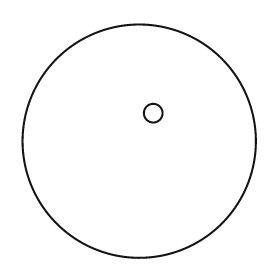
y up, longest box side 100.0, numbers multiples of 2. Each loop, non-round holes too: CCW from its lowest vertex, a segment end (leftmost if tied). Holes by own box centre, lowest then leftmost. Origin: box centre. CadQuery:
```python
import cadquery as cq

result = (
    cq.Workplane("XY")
    .moveTo(0.0, 0.0)
    .circle(50.0)
    .moveTo(6.0, 12.0)
    .circle(4.0)
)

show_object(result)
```